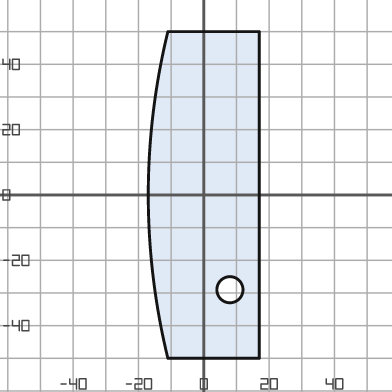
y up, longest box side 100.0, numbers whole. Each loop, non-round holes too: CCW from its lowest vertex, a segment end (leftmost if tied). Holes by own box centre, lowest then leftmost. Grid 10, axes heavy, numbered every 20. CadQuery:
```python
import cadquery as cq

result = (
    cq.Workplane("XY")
    .moveTo(-11.0, -50.0)
    .lineTo(17.0, -50.0)
    .lineTo(17.0, 50.0)
    .lineTo(-11.0, 50.0)
    .threePointArc((-17.0, 0.0), (-11.0, -50.0))
    .close()
    .moveTo(8.0, -29.0)
    .circle(4.0)
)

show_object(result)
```